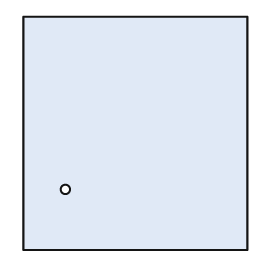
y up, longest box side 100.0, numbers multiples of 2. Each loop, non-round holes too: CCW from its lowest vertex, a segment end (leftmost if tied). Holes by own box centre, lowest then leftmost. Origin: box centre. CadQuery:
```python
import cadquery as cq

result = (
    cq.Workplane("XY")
    .moveTo(-48.0, -50.0)
    .lineTo(48.0, -50.0)
    .lineTo(48.0, 50.0)
    .lineTo(-48.0, 50.0)
    .close()
    .moveTo(-30.0, -24.0)
    .circle(2.0)
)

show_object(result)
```